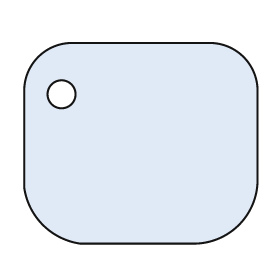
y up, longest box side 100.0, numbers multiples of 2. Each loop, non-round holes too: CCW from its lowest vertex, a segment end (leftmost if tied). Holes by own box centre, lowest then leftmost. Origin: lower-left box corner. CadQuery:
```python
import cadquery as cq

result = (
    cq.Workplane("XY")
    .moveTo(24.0, 0.0)
    .lineTo(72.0, 0.0)
    .threePointArc((92.0, 8.0), (100.0, 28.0))
    .lineTo(100.0, 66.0)
    .threePointArc((94.0, 80.0), (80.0, 86.0))
    .lineTo(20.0, 86.0)
    .threePointArc((6.0, 80.0), (0.0, 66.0))
    .lineTo(0.0, 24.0)
    .threePointArc((8.0, 8.0), (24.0, 0.0))
    .close()
    .moveTo(16.0, 64.0)
    .circle(6.0)
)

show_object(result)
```